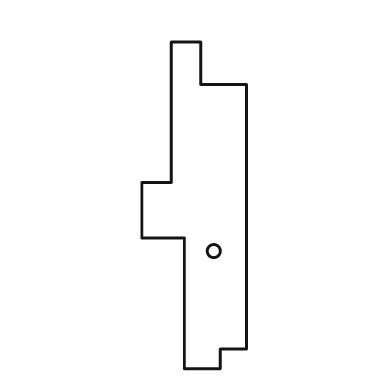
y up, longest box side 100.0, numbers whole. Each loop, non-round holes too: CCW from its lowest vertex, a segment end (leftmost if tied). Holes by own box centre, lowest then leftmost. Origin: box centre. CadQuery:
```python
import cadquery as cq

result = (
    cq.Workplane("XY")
    .moveTo(-3.0, -50.0)
    .lineTo(8.0, -50.0)
    .lineTo(8.0, -44.0)
    .lineTo(16.0, -44.0)
    .lineTo(16.0, 37.0)
    .lineTo(2.0, 37.0)
    .lineTo(2.0, 50.0)
    .lineTo(-7.0, 50.0)
    .lineTo(-7.0, 7.0)
    .lineTo(-16.0, 7.0)
    .lineTo(-16.0, -10.0)
    .lineTo(-3.0, -10.0)
    .close()
    .moveTo(6.0, -14.0)
    .circle(2.0)
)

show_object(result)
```